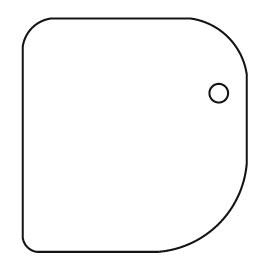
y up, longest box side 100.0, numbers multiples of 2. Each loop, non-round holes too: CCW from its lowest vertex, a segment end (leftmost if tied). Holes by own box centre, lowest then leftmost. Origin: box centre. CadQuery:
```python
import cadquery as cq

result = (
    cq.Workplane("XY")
    .moveTo(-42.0, -50.0)
    .lineTo(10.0, -50.0)
    .threePointArc((36.0, -38.0), (48.0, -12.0))
    .lineTo(48.0, 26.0)
    .threePointArc((40.0, 42.0), (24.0, 50.0))
    .lineTo(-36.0, 50.0)
    .threePointArc((-44.0, 46.0), (-48.0, 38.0))
    .lineTo(-48.0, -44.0)
    .threePointArc((-46.0, -48.0), (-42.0, -50.0))
    .close()
    .moveTo(36.0, 18.0)
    .circle(4.0)
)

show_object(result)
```